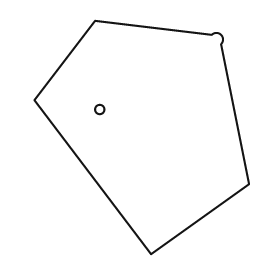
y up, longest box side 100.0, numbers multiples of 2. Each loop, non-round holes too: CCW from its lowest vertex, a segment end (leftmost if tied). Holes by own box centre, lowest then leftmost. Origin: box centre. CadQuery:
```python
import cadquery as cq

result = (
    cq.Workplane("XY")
    .moveTo(4.0, -50.0)
    .lineTo(46.0, -20.0)
    .lineTo(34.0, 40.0)
    .threePointArc((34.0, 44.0), (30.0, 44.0))
    .lineTo(-20.0, 50.0)
    .lineTo(-46.0, 16.0)
    .close()
    .moveTo(-18.0, 12.0)
    .circle(2.0)
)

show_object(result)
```